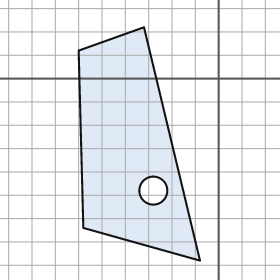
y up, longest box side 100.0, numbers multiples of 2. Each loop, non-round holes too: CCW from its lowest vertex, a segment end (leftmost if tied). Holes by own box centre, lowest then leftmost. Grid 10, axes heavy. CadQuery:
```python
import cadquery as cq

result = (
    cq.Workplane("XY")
    .moveTo(-8.0, -78.0)
    .lineTo(-32.0, 22.0)
    .lineTo(-60.0, 12.0)
    .lineTo(-58.0, -64.0)
    .close()
    .moveTo(-28.0, -48.0)
    .circle(6.0)
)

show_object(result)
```